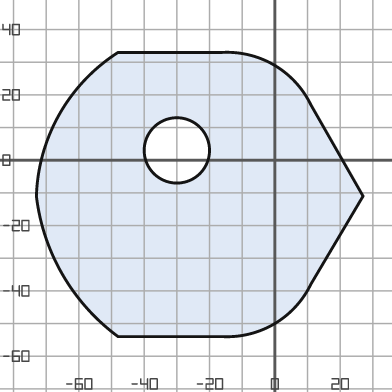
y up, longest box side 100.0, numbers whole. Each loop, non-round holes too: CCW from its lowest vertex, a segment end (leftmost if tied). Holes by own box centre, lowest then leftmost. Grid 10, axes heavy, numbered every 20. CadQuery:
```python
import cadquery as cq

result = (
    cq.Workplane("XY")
    .moveTo(-48.0, -54.0)
    .lineTo(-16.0, -54.0)
    .threePointArc((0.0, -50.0), (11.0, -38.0))
    .lineTo(27.0, -11.0)
    .lineTo(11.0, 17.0)
    .threePointArc((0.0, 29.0), (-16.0, 33.0))
    .lineTo(-48.0, 33.0)
    .threePointArc((-66.0, 14.0), (-73.0, -11.0))
    .threePointArc((-65.0, -35.0), (-48.0, -54.0))
    .close()
    .moveTo(-30.0, 3.0)
    .circle(10.0)
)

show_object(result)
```